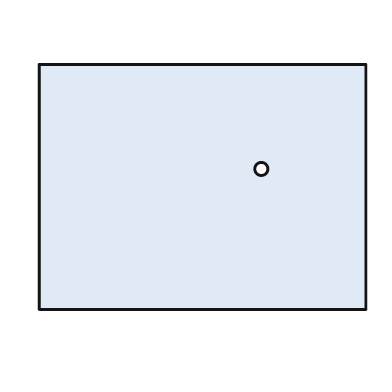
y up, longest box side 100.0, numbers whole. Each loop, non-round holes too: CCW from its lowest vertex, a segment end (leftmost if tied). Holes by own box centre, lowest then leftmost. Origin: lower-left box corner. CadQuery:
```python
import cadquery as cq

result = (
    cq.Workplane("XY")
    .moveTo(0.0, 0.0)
    .lineTo(100.0, 0.0)
    .lineTo(100.0, 75.0)
    .lineTo(0.0, 75.0)
    .close()
    .moveTo(68.0, 43.0)
    .circle(2.0)
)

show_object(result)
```